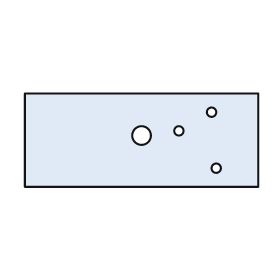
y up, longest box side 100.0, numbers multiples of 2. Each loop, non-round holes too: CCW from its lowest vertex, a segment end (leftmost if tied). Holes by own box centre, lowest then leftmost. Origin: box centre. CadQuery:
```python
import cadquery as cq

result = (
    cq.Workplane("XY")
    .moveTo(-50.0, -20.0)
    .lineTo(50.0, -20.0)
    .lineTo(50.0, 20.0)
    .lineTo(-50.0, 20.0)
    .close()
    .moveTo(32.0, -12.0)
    .circle(2.0)
    .moveTo(0.0, 2.0)
    .circle(4.0)
    .moveTo(16.0, 4.0)
    .circle(2.0)
    .moveTo(30.0, 12.0)
    .circle(2.0)
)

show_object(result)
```